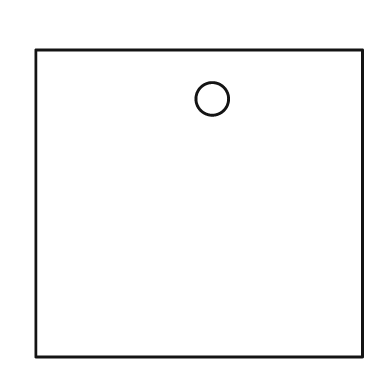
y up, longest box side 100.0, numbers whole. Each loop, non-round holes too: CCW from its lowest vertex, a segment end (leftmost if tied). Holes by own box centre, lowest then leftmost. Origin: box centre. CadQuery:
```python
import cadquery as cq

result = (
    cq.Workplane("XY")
    .moveTo(-50.0, -47.0)
    .lineTo(50.0, -47.0)
    .lineTo(50.0, 47.0)
    .lineTo(-50.0, 47.0)
    .close()
    .moveTo(4.0, 32.0)
    .circle(5.0)
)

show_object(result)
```